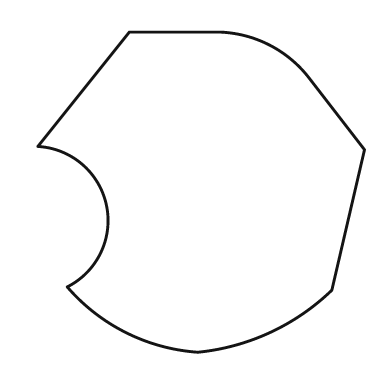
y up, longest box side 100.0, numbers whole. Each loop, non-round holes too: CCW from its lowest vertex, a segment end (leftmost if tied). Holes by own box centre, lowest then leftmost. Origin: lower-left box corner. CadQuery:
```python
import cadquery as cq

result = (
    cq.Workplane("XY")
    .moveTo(49.0, 0.0)
    .threePointArc((71.0, 6.0), (90.0, 19.0))
    .lineTo(100.0, 62.0)
    .lineTo(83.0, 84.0)
    .threePointArc((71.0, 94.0), (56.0, 98.0))
    .lineTo(28.0, 98.0)
    .lineTo(0.0, 63.0)
    .threePointArc((21.0, 45.0), (9.0, 20.0))
    .threePointArc((27.0, 6.0), (49.0, 0.0))
    .close()
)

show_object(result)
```